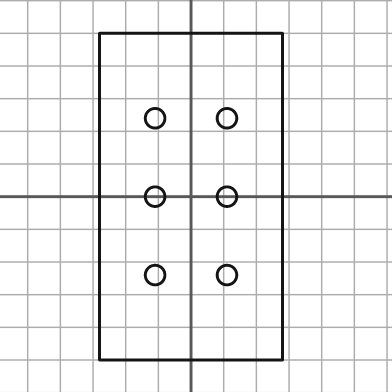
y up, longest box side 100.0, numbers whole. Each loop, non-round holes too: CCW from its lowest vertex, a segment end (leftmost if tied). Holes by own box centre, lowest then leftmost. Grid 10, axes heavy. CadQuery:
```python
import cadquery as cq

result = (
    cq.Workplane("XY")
    .moveTo(-28.0, -50.0)
    .lineTo(28.0, -50.0)
    .lineTo(28.0, 50.0)
    .lineTo(-28.0, 50.0)
    .close()
    .moveTo(-11.0, -24.0)
    .circle(3.0)
    .moveTo(11.0, -24.0)
    .circle(3.0)
    .moveTo(-11.0, 0.0)
    .circle(3.0)
    .moveTo(11.0, 0.0)
    .circle(3.0)
    .moveTo(-11.0, 24.0)
    .circle(3.0)
    .moveTo(11.0, 24.0)
    .circle(3.0)
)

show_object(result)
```